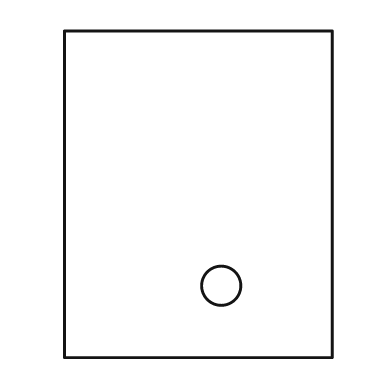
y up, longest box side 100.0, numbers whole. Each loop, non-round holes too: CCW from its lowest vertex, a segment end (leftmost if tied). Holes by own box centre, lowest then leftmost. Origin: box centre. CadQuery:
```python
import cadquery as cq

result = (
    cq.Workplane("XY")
    .moveTo(-41.0, -50.0)
    .lineTo(41.0, -50.0)
    .lineTo(41.0, 50.0)
    .lineTo(-41.0, 50.0)
    .close()
    .moveTo(7.0, -28.0)
    .circle(6.0)
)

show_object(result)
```